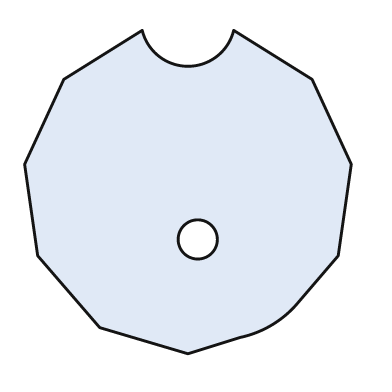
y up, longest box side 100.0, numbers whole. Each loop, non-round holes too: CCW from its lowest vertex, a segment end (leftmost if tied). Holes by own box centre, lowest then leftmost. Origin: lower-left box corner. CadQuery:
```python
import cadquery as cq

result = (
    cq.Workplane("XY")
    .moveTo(50.0, 0.0)
    .lineTo(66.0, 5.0)
    .threePointArc((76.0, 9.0), (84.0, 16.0))
    .lineTo(96.0, 30.0)
    .lineTo(100.0, 58.0)
    .lineTo(88.0, 84.0)
    .lineTo(64.0, 99.0)
    .threePointArc((50.0, 88.0), (36.0, 99.0))
    .lineTo(12.0, 84.0)
    .lineTo(0.0, 58.0)
    .lineTo(4.0, 30.0)
    .lineTo(23.0, 8.0)
    .close()
    .moveTo(53.0, 35.0)
    .circle(6.0)
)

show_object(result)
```